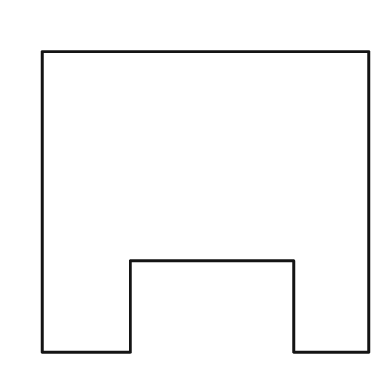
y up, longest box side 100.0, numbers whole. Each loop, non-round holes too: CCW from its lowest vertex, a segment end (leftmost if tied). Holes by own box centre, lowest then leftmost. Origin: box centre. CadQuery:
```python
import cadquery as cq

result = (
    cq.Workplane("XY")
    .moveTo(-50.0, -46.0)
    .lineTo(-23.0, -46.0)
    .lineTo(-23.0, -18.0)
    .lineTo(27.0, -18.0)
    .lineTo(27.0, -46.0)
    .lineTo(50.0, -46.0)
    .lineTo(50.0, 46.0)
    .lineTo(-50.0, 46.0)
    .close()
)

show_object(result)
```